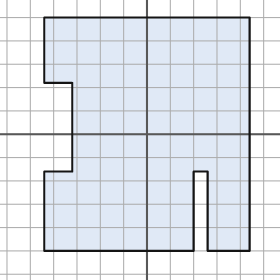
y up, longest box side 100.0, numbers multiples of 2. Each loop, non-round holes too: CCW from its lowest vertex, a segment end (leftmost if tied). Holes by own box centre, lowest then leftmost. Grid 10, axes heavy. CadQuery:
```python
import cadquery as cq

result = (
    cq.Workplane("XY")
    .moveTo(-44.0, -50.0)
    .lineTo(20.0, -50.0)
    .lineTo(20.0, -16.0)
    .lineTo(26.0, -16.0)
    .lineTo(26.0, -50.0)
    .lineTo(44.0, -50.0)
    .lineTo(44.0, 50.0)
    .lineTo(-44.0, 50.0)
    .lineTo(-44.0, 22.0)
    .lineTo(-32.0, 22.0)
    .lineTo(-32.0, -16.0)
    .lineTo(-44.0, -16.0)
    .close()
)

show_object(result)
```